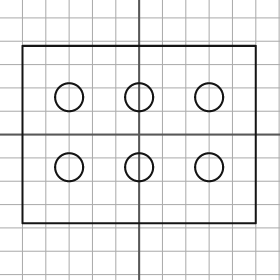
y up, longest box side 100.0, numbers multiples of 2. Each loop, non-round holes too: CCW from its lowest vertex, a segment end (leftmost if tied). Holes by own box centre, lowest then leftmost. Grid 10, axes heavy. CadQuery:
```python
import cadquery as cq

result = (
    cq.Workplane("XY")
    .moveTo(-50.0, -38.0)
    .lineTo(50.0, -38.0)
    .lineTo(50.0, 38.0)
    .lineTo(-50.0, 38.0)
    .close()
    .moveTo(-30.0, -14.0)
    .circle(6.0)
    .moveTo(0.0, -14.0)
    .circle(6.0)
    .moveTo(30.0, -14.0)
    .circle(6.0)
    .moveTo(-30.0, 16.0)
    .circle(6.0)
    .moveTo(0.0, 16.0)
    .circle(6.0)
    .moveTo(30.0, 16.0)
    .circle(6.0)
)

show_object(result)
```